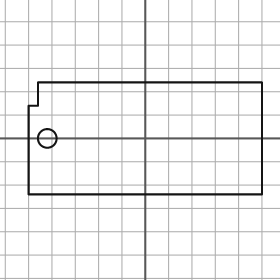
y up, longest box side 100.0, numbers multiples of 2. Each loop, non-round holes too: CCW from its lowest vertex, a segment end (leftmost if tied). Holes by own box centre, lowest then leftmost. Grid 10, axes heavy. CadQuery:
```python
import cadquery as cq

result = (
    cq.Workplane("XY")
    .moveTo(-50.0, -24.0)
    .lineTo(50.0, -24.0)
    .lineTo(50.0, 24.0)
    .lineTo(-46.0, 24.0)
    .lineTo(-46.0, 14.0)
    .lineTo(-50.0, 14.0)
    .close()
    .moveTo(-42.0, 0.0)
    .circle(4.0)
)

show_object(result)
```